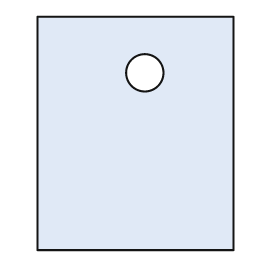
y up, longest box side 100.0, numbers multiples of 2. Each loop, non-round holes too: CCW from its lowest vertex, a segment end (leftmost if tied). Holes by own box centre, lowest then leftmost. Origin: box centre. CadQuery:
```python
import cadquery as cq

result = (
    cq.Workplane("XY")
    .moveTo(-42.0, -50.0)
    .lineTo(42.0, -50.0)
    .lineTo(42.0, 50.0)
    .lineTo(-42.0, 50.0)
    .close()
    .moveTo(4.0, 26.0)
    .circle(8.0)
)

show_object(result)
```